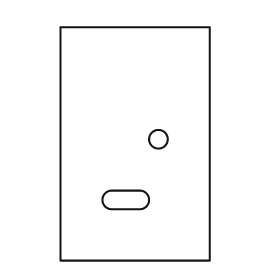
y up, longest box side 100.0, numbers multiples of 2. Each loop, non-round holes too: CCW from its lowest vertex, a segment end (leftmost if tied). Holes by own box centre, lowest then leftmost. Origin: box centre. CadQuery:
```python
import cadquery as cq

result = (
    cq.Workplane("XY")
    .moveTo(-32.0, -50.0)
    .lineTo(32.0, -50.0)
    .lineTo(32.0, 50.0)
    .lineTo(-32.0, 50.0)
    .close()
    .moveTo(-10.0, -28.0)
    .lineTo(2.0, -28.0)
    .threePointArc((6.0, -24.0), (2.0, -20.0))
    .lineTo(-10.0, -20.0)
    .threePointArc((-14.0, -24.0), (-10.0, -28.0))
    .close()
    .moveTo(10.0, 2.0)
    .circle(4.0)
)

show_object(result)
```